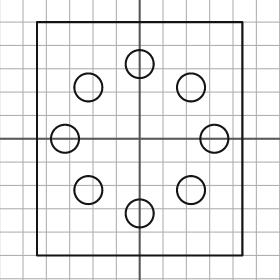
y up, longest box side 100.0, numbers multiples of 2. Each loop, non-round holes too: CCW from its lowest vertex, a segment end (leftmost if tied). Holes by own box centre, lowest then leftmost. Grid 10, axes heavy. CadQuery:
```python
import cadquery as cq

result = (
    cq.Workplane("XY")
    .moveTo(-44.0, -50.0)
    .lineTo(44.0, -50.0)
    .lineTo(44.0, 50.0)
    .lineTo(-44.0, 50.0)
    .close()
    .moveTo(0.0, -32.0)
    .circle(6.0)
    .moveTo(-22.0, -22.0)
    .circle(6.0)
    .moveTo(22.0, -22.0)
    .circle(6.0)
    .moveTo(-32.0, 0.0)
    .circle(6.0)
    .moveTo(32.0, 0.0)
    .circle(6.0)
    .moveTo(-22.0, 22.0)
    .circle(6.0)
    .moveTo(22.0, 22.0)
    .circle(6.0)
    .moveTo(0.0, 32.0)
    .circle(6.0)
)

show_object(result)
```